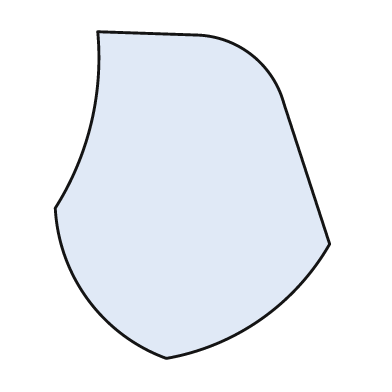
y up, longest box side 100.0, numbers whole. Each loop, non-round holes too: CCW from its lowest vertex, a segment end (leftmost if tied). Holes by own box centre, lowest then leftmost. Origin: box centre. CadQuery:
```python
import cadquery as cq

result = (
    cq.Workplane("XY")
    .moveTo(-8.0, -50.0)
    .threePointArc((21.0, -38.0), (42.0, -15.0))
    .lineTo(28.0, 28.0)
    .threePointArc((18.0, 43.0), (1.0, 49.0))
    .lineTo(-29.0, 50.0)
    .threePointArc((-31.0, 22.0), (-42.0, -4.0))
    .threePointArc((-32.0, -32.0), (-8.0, -50.0))
    .close()
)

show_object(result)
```